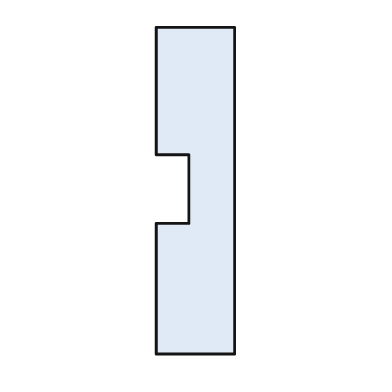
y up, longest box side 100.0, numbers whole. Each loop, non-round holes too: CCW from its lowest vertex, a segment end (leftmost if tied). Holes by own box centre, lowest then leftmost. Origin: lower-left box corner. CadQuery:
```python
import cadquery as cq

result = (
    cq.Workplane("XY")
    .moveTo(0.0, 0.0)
    .lineTo(24.0, 0.0)
    .lineTo(24.0, 100.0)
    .lineTo(0.0, 100.0)
    .lineTo(0.0, 61.0)
    .lineTo(10.0, 61.0)
    .lineTo(10.0, 40.0)
    .lineTo(0.0, 40.0)
    .close()
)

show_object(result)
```